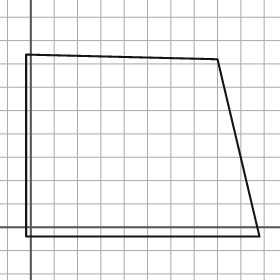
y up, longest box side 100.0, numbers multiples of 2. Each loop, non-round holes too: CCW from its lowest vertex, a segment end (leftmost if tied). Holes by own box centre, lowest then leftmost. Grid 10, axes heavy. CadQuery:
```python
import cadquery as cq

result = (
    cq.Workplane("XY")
    .moveTo(-2.0, -4.0)
    .lineTo(98.0, -4.0)
    .lineTo(80.0, 72.0)
    .lineTo(-2.0, 74.0)
    .close()
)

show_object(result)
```